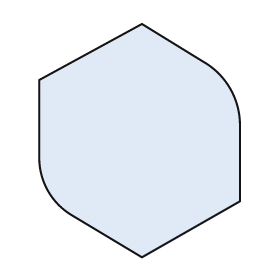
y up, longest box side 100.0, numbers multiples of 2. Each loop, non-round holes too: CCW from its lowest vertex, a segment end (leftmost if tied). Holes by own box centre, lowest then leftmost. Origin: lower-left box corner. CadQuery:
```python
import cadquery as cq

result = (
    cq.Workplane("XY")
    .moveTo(44.0, 0.0)
    .lineTo(86.0, 24.0)
    .lineTo(86.0, 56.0)
    .threePointArc((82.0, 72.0), (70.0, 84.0))
    .lineTo(44.0, 100.0)
    .lineTo(0.0, 76.0)
    .lineTo(0.0, 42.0)
    .threePointArc((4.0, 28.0), (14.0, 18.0))
    .close()
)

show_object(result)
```